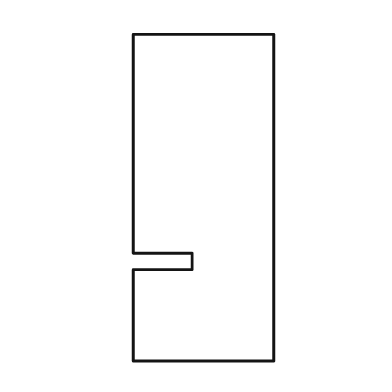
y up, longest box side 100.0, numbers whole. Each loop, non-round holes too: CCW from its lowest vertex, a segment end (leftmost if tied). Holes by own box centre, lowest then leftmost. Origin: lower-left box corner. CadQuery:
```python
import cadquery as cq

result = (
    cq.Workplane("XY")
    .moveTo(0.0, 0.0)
    .lineTo(43.0, 0.0)
    .lineTo(43.0, 100.0)
    .lineTo(0.0, 100.0)
    .lineTo(0.0, 33.0)
    .lineTo(18.0, 33.0)
    .lineTo(18.0, 28.0)
    .lineTo(0.0, 28.0)
    .close()
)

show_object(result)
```